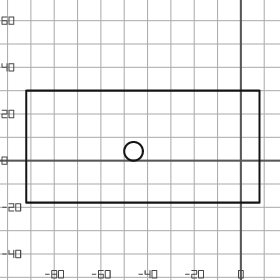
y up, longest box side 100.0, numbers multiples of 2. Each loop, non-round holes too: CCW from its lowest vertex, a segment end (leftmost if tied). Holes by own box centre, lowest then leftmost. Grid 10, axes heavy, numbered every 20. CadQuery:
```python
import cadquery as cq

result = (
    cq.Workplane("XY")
    .moveTo(-92.0, -18.0)
    .lineTo(8.0, -18.0)
    .lineTo(8.0, 30.0)
    .lineTo(-92.0, 30.0)
    .close()
    .moveTo(-46.0, 4.0)
    .circle(4.0)
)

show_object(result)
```